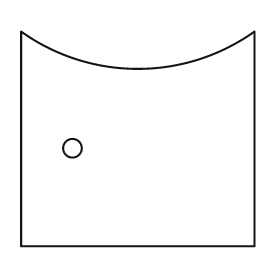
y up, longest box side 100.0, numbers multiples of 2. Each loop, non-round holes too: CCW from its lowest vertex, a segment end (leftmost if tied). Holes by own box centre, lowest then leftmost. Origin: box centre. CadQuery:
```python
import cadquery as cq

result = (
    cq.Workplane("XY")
    .moveTo(-50.0, -46.0)
    .lineTo(50.0, -46.0)
    .lineTo(50.0, 46.0)
    .threePointArc((0.0, 30.0), (-50.0, 46.0))
    .close()
    .moveTo(-28.0, -4.0)
    .circle(4.0)
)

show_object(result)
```